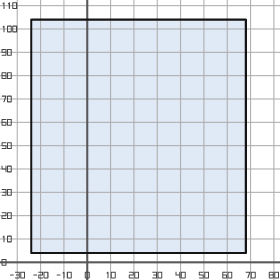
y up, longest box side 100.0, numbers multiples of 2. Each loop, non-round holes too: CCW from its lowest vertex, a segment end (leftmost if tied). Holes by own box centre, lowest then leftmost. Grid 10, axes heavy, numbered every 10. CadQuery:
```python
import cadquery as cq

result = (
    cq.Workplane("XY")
    .moveTo(-24.0, 4.0)
    .lineTo(68.0, 4.0)
    .lineTo(68.0, 104.0)
    .lineTo(-24.0, 104.0)
    .close()
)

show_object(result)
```